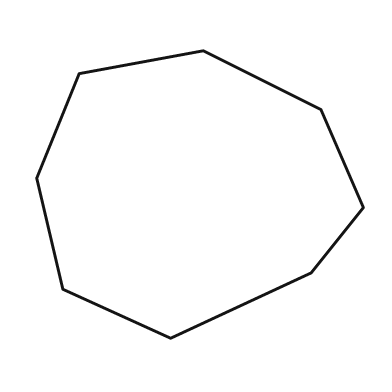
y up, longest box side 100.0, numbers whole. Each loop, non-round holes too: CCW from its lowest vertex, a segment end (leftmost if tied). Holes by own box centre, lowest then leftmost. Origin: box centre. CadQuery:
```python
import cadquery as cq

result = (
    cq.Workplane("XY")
    .moveTo(-9.0, -44.0)
    .lineTo(34.0, -24.0)
    .lineTo(50.0, -4.0)
    .lineTo(37.0, 26.0)
    .lineTo(1.0, 44.0)
    .lineTo(-37.0, 37.0)
    .lineTo(-50.0, 5.0)
    .lineTo(-42.0, -29.0)
    .close()
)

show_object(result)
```